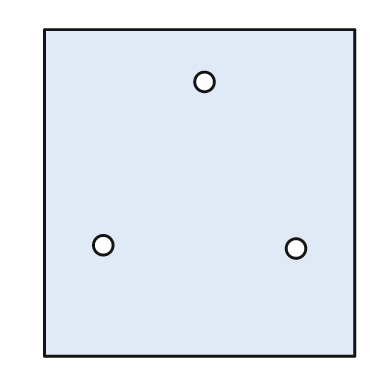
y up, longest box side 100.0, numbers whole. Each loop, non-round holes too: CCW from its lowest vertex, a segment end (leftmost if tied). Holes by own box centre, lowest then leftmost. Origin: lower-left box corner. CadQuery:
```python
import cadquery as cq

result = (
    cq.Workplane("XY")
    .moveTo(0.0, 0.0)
    .lineTo(95.0, 0.0)
    .lineTo(95.0, 100.0)
    .lineTo(0.0, 100.0)
    .close()
    .moveTo(77.0, 33.0)
    .circle(3.0)
    .moveTo(18.0, 34.0)
    .circle(3.0)
    .moveTo(49.0, 84.0)
    .circle(3.0)
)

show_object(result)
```